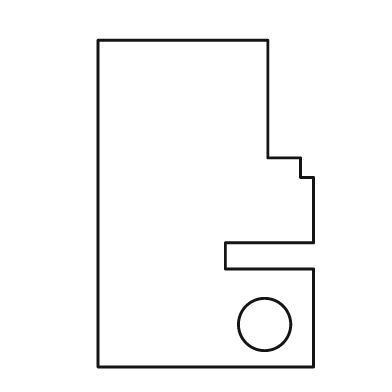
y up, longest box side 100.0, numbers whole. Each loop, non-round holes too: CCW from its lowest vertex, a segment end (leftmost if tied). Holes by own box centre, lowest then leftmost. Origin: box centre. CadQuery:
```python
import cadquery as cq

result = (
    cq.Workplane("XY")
    .moveTo(-33.0, -50.0)
    .lineTo(33.0, -50.0)
    .lineTo(33.0, -20.0)
    .lineTo(6.0, -20.0)
    .lineTo(6.0, -12.0)
    .lineTo(33.0, -12.0)
    .lineTo(33.0, 8.0)
    .lineTo(29.0, 8.0)
    .lineTo(29.0, 14.0)
    .lineTo(19.0, 14.0)
    .lineTo(19.0, 50.0)
    .lineTo(-33.0, 50.0)
    .close()
    .moveTo(18.0, -37.0)
    .circle(8.0)
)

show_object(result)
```